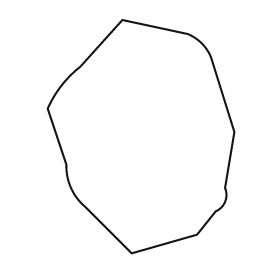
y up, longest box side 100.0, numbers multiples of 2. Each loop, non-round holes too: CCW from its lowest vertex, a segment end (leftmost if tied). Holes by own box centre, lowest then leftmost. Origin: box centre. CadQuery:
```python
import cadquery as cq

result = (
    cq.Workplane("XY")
    .moveTo(-4.0, -50.0)
    .lineTo(24.0, -42.0)
    .lineTo(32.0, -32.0)
    .threePointArc((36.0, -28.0), (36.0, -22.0))
    .lineTo(40.0, 2.0)
    .lineTo(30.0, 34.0)
    .threePointArc((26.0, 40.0), (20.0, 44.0))
    .lineTo(-8.0, 50.0)
    .lineTo(-26.0, 30.0)
    .threePointArc((-34.0, 22.0), (-40.0, 12.0))
    .lineTo(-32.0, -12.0)
    .threePointArc((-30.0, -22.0), (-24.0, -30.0))
    .close()
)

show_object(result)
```